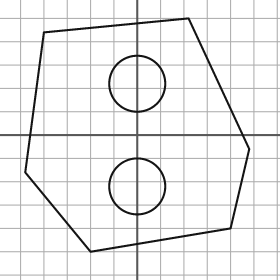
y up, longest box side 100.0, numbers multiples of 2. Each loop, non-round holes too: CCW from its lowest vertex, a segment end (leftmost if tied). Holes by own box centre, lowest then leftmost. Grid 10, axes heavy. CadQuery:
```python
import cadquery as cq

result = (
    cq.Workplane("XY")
    .moveTo(-20.0, -50.0)
    .lineTo(40.0, -40.0)
    .lineTo(48.0, -6.0)
    .lineTo(22.0, 50.0)
    .lineTo(-40.0, 44.0)
    .lineTo(-48.0, -16.0)
    .close()
    .moveTo(0.0, -22.0)
    .circle(12.0)
    .moveTo(0.0, 22.0)
    .circle(12.0)
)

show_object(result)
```